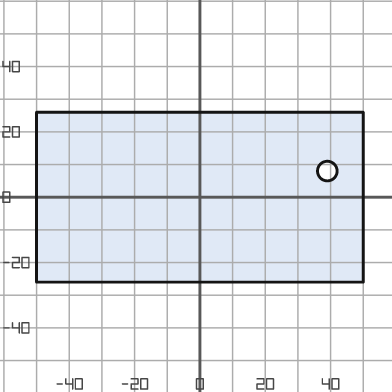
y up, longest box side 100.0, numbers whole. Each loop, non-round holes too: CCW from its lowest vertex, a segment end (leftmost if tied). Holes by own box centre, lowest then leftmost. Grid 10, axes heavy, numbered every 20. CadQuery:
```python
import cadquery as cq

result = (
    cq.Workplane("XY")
    .moveTo(-50.0, -26.0)
    .lineTo(50.0, -26.0)
    .lineTo(50.0, 26.0)
    .lineTo(-50.0, 26.0)
    .close()
    .moveTo(39.0, 8.0)
    .circle(3.0)
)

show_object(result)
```